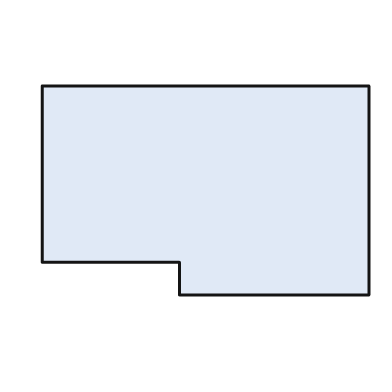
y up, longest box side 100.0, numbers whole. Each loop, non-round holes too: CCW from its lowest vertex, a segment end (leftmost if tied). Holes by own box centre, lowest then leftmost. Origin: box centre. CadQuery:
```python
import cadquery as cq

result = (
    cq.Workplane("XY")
    .moveTo(-8.0, -32.0)
    .lineTo(50.0, -32.0)
    .lineTo(50.0, 32.0)
    .lineTo(-50.0, 32.0)
    .lineTo(-50.0, -22.0)
    .lineTo(-8.0, -22.0)
    .close()
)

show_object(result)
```